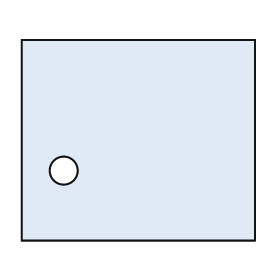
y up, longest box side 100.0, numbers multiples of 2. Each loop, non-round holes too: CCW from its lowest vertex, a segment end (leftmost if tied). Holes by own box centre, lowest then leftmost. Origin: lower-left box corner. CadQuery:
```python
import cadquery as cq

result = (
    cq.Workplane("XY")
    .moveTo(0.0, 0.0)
    .lineTo(100.0, 0.0)
    .lineTo(100.0, 86.0)
    .lineTo(0.0, 86.0)
    .close()
    .moveTo(18.0, 30.0)
    .circle(6.0)
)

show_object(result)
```